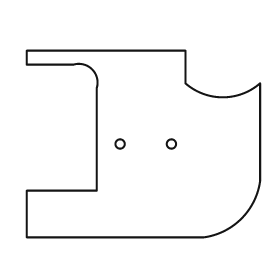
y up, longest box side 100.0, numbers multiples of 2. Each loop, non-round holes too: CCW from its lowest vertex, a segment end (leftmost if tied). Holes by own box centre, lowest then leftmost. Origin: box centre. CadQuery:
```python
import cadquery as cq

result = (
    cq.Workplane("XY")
    .moveTo(-50.0, -40.0)
    .lineTo(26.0, -40.0)
    .threePointArc((42.0, -32.0), (50.0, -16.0))
    .lineTo(50.0, 26.0)
    .threePointArc((34.0, 20.0), (18.0, 26.0))
    .lineTo(18.0, 40.0)
    .lineTo(-50.0, 40.0)
    .lineTo(-50.0, 34.0)
    .lineTo(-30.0, 34.0)
    .threePointArc((-22.0, 32.0), (-20.0, 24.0))
    .lineTo(-20.0, -20.0)
    .lineTo(-50.0, -20.0)
    .close()
    .moveTo(-10.0, 0.0)
    .circle(2.0)
    .moveTo(12.0, 0.0)
    .circle(2.0)
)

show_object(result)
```